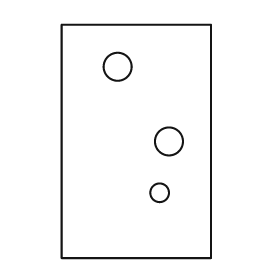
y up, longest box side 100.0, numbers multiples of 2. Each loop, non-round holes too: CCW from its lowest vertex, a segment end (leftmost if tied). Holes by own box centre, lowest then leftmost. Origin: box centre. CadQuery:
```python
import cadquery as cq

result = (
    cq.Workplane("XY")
    .moveTo(-32.0, -50.0)
    .lineTo(32.0, -50.0)
    .lineTo(32.0, 50.0)
    .lineTo(-32.0, 50.0)
    .close()
    .moveTo(10.0, -22.0)
    .circle(4.0)
    .moveTo(14.0, 0.0)
    .circle(6.0)
    .moveTo(-8.0, 32.0)
    .circle(6.0)
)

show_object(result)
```